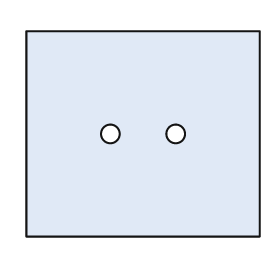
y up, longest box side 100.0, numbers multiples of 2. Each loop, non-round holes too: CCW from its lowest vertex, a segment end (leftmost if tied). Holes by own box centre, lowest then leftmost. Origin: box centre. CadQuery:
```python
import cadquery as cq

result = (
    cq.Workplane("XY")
    .moveTo(-50.0, -44.0)
    .lineTo(50.0, -44.0)
    .lineTo(50.0, 44.0)
    .lineTo(-50.0, 44.0)
    .close()
    .moveTo(-14.0, 0.0)
    .circle(4.0)
    .moveTo(14.0, 0.0)
    .circle(4.0)
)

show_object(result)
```